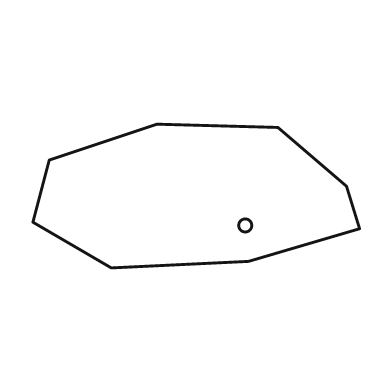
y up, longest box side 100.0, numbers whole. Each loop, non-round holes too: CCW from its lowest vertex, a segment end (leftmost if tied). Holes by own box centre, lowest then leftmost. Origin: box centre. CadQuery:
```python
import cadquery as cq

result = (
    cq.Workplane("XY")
    .moveTo(-26.0, -22.0)
    .lineTo(16.0, -20.0)
    .lineTo(50.0, -10.0)
    .lineTo(46.0, 3.0)
    .lineTo(25.0, 21.0)
    .lineTo(-12.0, 22.0)
    .lineTo(-45.0, 11.0)
    .lineTo(-50.0, -8.0)
    .close()
    .moveTo(15.0, -9.0)
    .circle(2.0)
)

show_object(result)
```